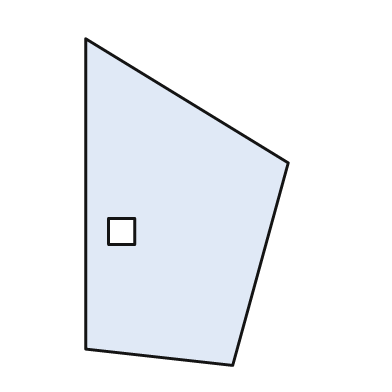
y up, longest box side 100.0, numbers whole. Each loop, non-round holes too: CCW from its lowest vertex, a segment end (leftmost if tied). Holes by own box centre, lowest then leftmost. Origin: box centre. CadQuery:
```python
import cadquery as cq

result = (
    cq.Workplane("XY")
    .moveTo(14.0, -50.0)
    .lineTo(31.0, 12.0)
    .lineTo(-31.0, 50.0)
    .lineTo(-31.0, -45.0)
    .close()
    .moveTo(-24.0, -13.0)
    .lineTo(-16.0, -13.0)
    .lineTo(-16.0, -5.0)
    .lineTo(-24.0, -5.0)
    .close()
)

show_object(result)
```